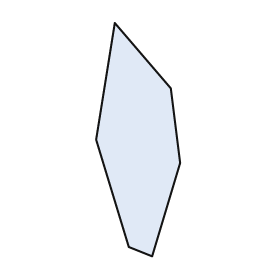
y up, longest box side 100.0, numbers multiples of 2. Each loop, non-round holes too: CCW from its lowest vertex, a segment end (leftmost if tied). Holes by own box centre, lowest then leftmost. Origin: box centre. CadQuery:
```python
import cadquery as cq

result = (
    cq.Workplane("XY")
    .moveTo(6.0, -50.0)
    .lineTo(18.0, -10.0)
    .lineTo(14.0, 22.0)
    .lineTo(-10.0, 50.0)
    .lineTo(-18.0, 0.0)
    .lineTo(-4.0, -46.0)
    .close()
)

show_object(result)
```